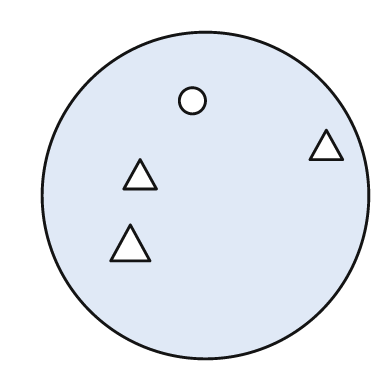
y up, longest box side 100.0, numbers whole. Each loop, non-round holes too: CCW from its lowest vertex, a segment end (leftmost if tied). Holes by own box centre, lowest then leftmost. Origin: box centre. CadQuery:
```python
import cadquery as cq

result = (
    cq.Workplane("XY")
    .moveTo(0.0, 0.0)
    .circle(50.0)
    .moveTo(-29.0, -20.0)
    .lineTo(-17.0, -20.0)
    .lineTo(-23.0, -9.0)
    .close()
    .moveTo(-25.0, 2.0)
    .lineTo(-15.0, 2.0)
    .lineTo(-20.0, 11.0)
    .close()
    .moveTo(32.0, 11.0)
    .lineTo(42.0, 11.0)
    .lineTo(37.0, 20.0)
    .close()
    .moveTo(-4.0, 29.0)
    .circle(4.0)
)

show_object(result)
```